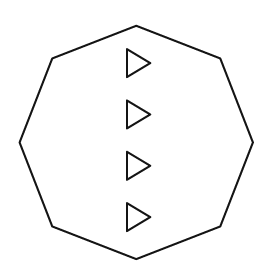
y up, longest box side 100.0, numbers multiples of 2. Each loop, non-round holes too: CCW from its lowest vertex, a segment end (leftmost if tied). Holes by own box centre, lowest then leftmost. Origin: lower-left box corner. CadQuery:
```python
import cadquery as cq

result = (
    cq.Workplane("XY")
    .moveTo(50.0, 0.0)
    .lineTo(86.0, 14.0)
    .lineTo(100.0, 50.0)
    .lineTo(86.0, 86.0)
    .lineTo(50.0, 100.0)
    .lineTo(14.0, 86.0)
    .lineTo(0.0, 50.0)
    .lineTo(14.0, 14.0)
    .close()
    .moveTo(46.0, 12.0)
    .lineTo(56.0, 18.0)
    .lineTo(46.0, 24.0)
    .close()
    .moveTo(46.0, 34.0)
    .lineTo(56.0, 40.0)
    .lineTo(46.0, 46.0)
    .close()
    .moveTo(46.0, 56.0)
    .lineTo(56.0, 62.0)
    .lineTo(46.0, 68.0)
    .close()
    .moveTo(46.0, 78.0)
    .lineTo(56.0, 84.0)
    .lineTo(46.0, 90.0)
    .close()
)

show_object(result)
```